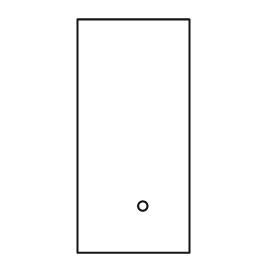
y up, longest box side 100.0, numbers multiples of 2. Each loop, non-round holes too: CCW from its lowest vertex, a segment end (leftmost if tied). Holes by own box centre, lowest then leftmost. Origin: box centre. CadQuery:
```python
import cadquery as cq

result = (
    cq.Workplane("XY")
    .moveTo(-24.0, -50.0)
    .lineTo(24.0, -50.0)
    .lineTo(24.0, 50.0)
    .lineTo(-24.0, 50.0)
    .close()
    .moveTo(4.0, -30.0)
    .circle(2.0)
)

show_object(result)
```